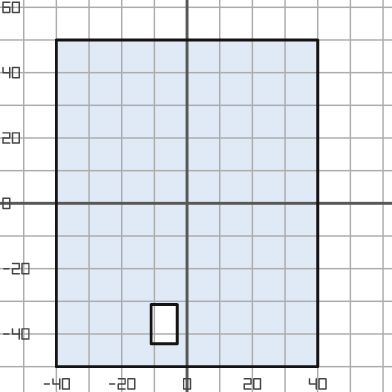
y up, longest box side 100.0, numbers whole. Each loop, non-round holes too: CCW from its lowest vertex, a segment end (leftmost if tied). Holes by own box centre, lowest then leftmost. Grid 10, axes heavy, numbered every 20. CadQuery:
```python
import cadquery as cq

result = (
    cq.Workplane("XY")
    .moveTo(-40.0, -50.0)
    .lineTo(40.0, -50.0)
    .lineTo(40.0, 50.0)
    .lineTo(-40.0, 50.0)
    .close()
    .moveTo(-11.0, -43.0)
    .lineTo(-3.0, -43.0)
    .lineTo(-3.0, -31.0)
    .lineTo(-11.0, -31.0)
    .close()
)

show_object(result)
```